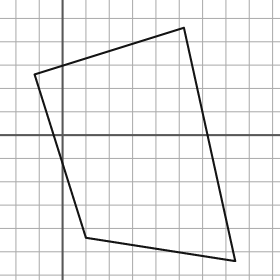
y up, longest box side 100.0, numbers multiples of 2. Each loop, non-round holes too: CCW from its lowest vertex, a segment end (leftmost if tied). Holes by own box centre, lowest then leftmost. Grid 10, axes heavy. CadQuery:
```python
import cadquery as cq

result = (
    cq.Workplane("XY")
    .moveTo(74.0, -54.0)
    .lineTo(52.0, 46.0)
    .lineTo(-12.0, 26.0)
    .lineTo(10.0, -44.0)
    .close()
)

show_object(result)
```